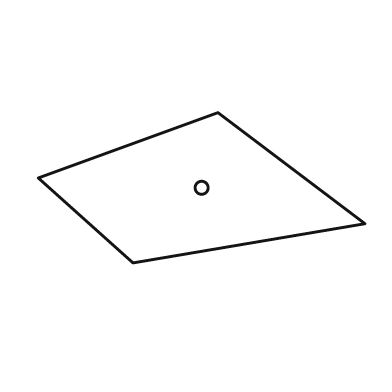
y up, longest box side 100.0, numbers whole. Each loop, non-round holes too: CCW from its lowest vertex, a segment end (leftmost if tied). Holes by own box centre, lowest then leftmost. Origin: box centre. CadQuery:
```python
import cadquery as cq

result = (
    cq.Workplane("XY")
    .moveTo(-21.0, -23.0)
    .lineTo(50.0, -11.0)
    .lineTo(5.0, 23.0)
    .lineTo(-50.0, 3.0)
    .close()
    .moveTo(0.0, 0.0)
    .circle(2.0)
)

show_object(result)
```